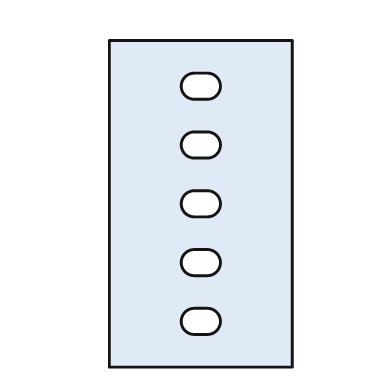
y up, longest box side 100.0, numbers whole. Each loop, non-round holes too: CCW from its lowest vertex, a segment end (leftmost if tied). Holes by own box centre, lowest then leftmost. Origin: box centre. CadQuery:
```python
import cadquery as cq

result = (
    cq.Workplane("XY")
    .moveTo(-28.0, -50.0)
    .lineTo(28.0, -50.0)
    .lineTo(28.0, 50.0)
    .lineTo(-28.0, 50.0)
    .close()
    .moveTo(-2.0, -40.0)
    .lineTo(2.0, -40.0)
    .threePointArc((6.0, -36.0), (2.0, -32.0))
    .lineTo(-2.0, -32.0)
    .threePointArc((-6.0, -36.0), (-2.0, -40.0))
    .close()
    .moveTo(-2.0, -22.0)
    .lineTo(2.0, -22.0)
    .threePointArc((6.0, -18.0), (2.0, -14.0))
    .lineTo(-2.0, -14.0)
    .threePointArc((-6.0, -18.0), (-2.0, -22.0))
    .close()
    .moveTo(-2.0, -4.0)
    .lineTo(2.0, -4.0)
    .threePointArc((6.0, 0.0), (2.0, 4.0))
    .lineTo(-2.0, 4.0)
    .threePointArc((-6.0, 0.0), (-2.0, -4.0))
    .close()
    .moveTo(-2.0, 14.0)
    .lineTo(2.0, 14.0)
    .threePointArc((6.0, 18.0), (2.0, 22.0))
    .lineTo(-2.0, 22.0)
    .threePointArc((-6.0, 18.0), (-2.0, 14.0))
    .close()
    .moveTo(-2.0, 32.0)
    .lineTo(2.0, 32.0)
    .threePointArc((6.0, 36.0), (2.0, 40.0))
    .lineTo(-2.0, 40.0)
    .threePointArc((-6.0, 36.0), (-2.0, 32.0))
    .close()
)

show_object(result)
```